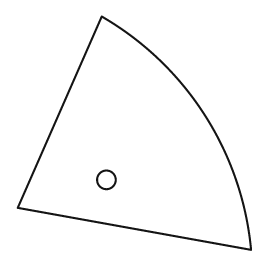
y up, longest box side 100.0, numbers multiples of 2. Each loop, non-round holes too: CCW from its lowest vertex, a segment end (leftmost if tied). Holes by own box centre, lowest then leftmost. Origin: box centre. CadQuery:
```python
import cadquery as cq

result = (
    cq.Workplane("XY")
    .moveTo(50.0, -50.0)
    .threePointArc((30.0, 8.0), (-14.0, 50.0))
    .lineTo(-50.0, -32.0)
    .close()
    .moveTo(-12.0, -20.0)
    .circle(4.0)
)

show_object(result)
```